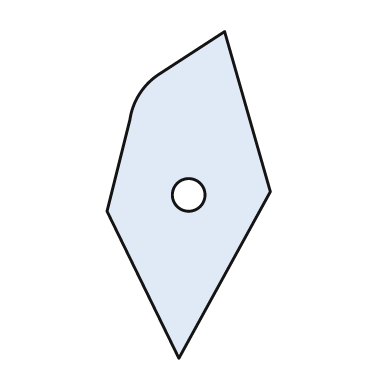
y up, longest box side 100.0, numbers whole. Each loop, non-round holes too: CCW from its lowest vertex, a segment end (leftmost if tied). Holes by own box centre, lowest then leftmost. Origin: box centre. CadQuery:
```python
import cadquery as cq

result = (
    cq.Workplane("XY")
    .moveTo(-3.0, -50.0)
    .lineTo(25.0, 1.0)
    .lineTo(11.0, 50.0)
    .lineTo(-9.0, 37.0)
    .threePointArc((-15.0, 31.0), (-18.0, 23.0))
    .lineTo(-25.0, -5.0)
    .close()
    .moveTo(0.0, 0.0)
    .circle(5.0)
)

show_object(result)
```